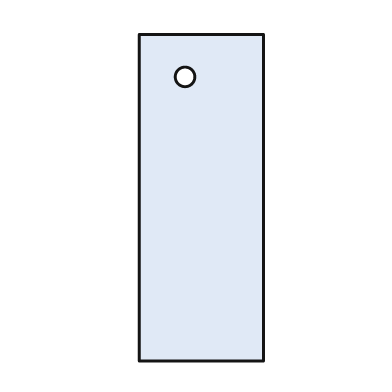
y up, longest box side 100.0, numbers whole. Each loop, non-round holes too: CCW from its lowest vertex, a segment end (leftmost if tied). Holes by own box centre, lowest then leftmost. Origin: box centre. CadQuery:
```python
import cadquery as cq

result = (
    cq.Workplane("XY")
    .moveTo(-19.0, -50.0)
    .lineTo(19.0, -50.0)
    .lineTo(19.0, 50.0)
    .lineTo(-19.0, 50.0)
    .close()
    .moveTo(-5.0, 37.0)
    .circle(3.0)
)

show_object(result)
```